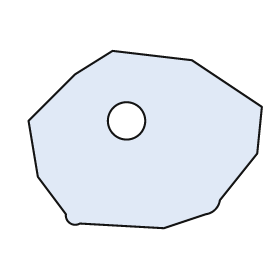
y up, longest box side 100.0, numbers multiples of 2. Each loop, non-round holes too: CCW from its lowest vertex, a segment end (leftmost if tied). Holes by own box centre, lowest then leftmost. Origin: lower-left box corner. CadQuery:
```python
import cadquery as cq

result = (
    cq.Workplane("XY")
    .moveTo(58.0, 0.0)
    .lineTo(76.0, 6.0)
    .threePointArc((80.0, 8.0), (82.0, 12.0))
    .lineTo(98.0, 32.0)
    .lineTo(100.0, 52.0)
    .lineTo(70.0, 72.0)
    .lineTo(36.0, 76.0)
    .lineTo(20.0, 66.0)
    .lineTo(0.0, 46.0)
    .lineTo(4.0, 22.0)
    .lineTo(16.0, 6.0)
    .threePointArc((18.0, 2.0), (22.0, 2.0))
    .close()
    .moveTo(42.0, 46.0)
    .circle(8.0)
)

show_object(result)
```